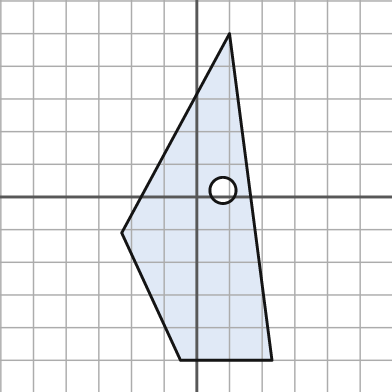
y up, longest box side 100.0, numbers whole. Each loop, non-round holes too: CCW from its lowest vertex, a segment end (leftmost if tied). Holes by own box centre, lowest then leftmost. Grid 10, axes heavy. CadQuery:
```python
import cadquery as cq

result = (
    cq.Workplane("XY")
    .moveTo(-5.0, -50.0)
    .lineTo(23.0, -50.0)
    .lineTo(10.0, 50.0)
    .lineTo(-23.0, -11.0)
    .close()
    .moveTo(8.0, 2.0)
    .circle(4.0)
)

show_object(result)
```